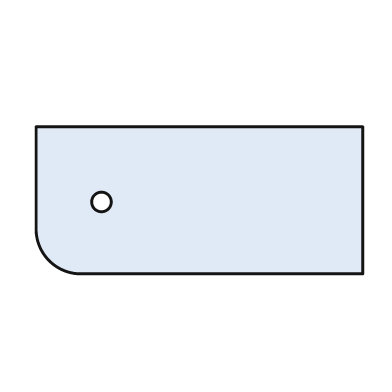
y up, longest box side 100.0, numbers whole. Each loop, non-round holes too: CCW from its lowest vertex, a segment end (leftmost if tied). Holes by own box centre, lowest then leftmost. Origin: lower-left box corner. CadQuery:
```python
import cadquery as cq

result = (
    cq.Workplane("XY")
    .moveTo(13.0, 0.0)
    .lineTo(100.0, 0.0)
    .lineTo(100.0, 45.0)
    .lineTo(0.0, 45.0)
    .lineTo(0.0, 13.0)
    .threePointArc((4.0, 4.0), (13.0, 0.0))
    .close()
    .moveTo(20.0, 22.0)
    .circle(3.0)
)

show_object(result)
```